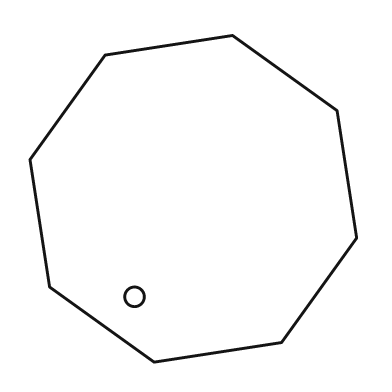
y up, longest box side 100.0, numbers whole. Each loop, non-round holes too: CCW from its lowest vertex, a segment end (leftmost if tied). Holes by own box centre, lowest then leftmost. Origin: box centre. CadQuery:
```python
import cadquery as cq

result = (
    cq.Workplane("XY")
    .moveTo(-12.0, -50.0)
    .lineTo(27.0, -44.0)
    .lineTo(50.0, -12.0)
    .lineTo(44.0, 27.0)
    .lineTo(12.0, 50.0)
    .lineTo(-27.0, 44.0)
    .lineTo(-50.0, 12.0)
    .lineTo(-44.0, -27.0)
    .close()
    .moveTo(-18.0, -30.0)
    .circle(3.0)
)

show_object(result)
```